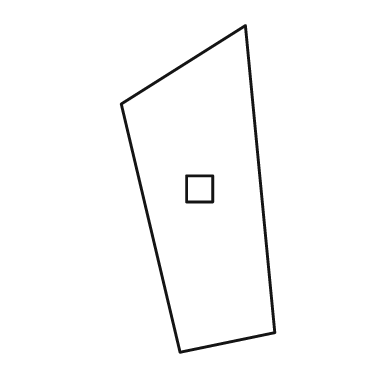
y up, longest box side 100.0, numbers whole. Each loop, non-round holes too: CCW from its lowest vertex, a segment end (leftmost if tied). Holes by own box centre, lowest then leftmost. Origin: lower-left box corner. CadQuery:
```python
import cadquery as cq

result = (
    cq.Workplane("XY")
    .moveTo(18.0, 0.0)
    .lineTo(47.0, 6.0)
    .lineTo(38.0, 100.0)
    .lineTo(0.0, 76.0)
    .close()
    .moveTo(20.0, 46.0)
    .lineTo(28.0, 46.0)
    .lineTo(28.0, 54.0)
    .lineTo(20.0, 54.0)
    .close()
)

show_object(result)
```